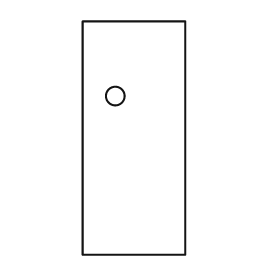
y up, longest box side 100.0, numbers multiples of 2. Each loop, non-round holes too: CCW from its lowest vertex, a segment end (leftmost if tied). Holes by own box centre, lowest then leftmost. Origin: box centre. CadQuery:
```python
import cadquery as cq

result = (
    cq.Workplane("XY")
    .moveTo(-22.0, -50.0)
    .lineTo(22.0, -50.0)
    .lineTo(22.0, 50.0)
    .lineTo(-22.0, 50.0)
    .close()
    .moveTo(-8.0, 18.0)
    .circle(4.0)
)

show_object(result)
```